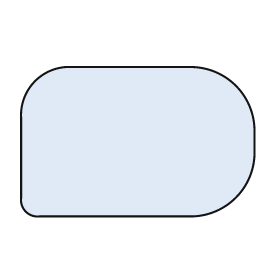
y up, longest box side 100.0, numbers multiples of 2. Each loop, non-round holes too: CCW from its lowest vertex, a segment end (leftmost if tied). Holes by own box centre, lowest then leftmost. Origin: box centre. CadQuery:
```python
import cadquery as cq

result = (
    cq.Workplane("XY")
    .moveTo(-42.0, -32.0)
    .lineTo(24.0, -32.0)
    .threePointArc((42.0, -24.0), (50.0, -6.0))
    .lineTo(50.0, 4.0)
    .threePointArc((42.0, 24.0), (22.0, 32.0))
    .lineTo(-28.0, 32.0)
    .threePointArc((-44.0, 26.0), (-50.0, 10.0))
    .lineTo(-50.0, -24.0)
    .threePointArc((-48.0, -30.0), (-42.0, -32.0))
    .close()
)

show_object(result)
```